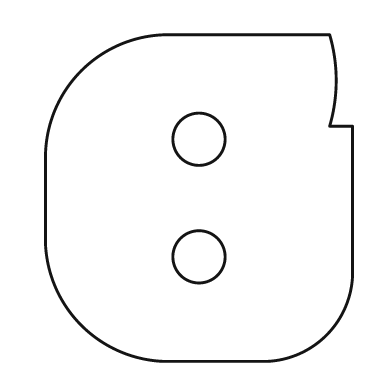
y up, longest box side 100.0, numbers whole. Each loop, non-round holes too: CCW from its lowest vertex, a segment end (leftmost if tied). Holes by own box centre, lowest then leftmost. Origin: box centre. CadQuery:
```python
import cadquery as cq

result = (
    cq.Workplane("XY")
    .moveTo(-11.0, -50.0)
    .lineTo(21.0, -50.0)
    .threePointArc((39.0, -42.0), (47.0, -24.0))
    .lineTo(47.0, 22.0)
    .lineTo(40.0, 22.0)
    .threePointArc((42.0, 36.0), (40.0, 50.0))
    .lineTo(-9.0, 50.0)
    .threePointArc((-36.0, 39.0), (-47.0, 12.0))
    .lineTo(-47.0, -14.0)
    .threePointArc((-36.0, -39.0), (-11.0, -50.0))
    .close()
    .moveTo(0.0, -18.0)
    .circle(8.0)
    .moveTo(0.0, 18.0)
    .circle(8.0)
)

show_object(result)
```